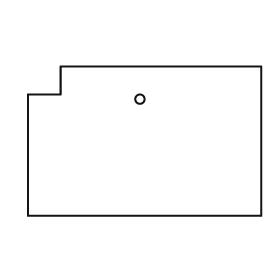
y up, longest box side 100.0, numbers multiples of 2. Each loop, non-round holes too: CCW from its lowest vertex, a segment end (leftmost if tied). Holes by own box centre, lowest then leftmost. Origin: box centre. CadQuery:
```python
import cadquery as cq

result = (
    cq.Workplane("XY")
    .moveTo(-50.0, -32.0)
    .lineTo(50.0, -32.0)
    .lineTo(50.0, 32.0)
    .lineTo(-36.0, 32.0)
    .lineTo(-36.0, 20.0)
    .lineTo(-50.0, 20.0)
    .close()
    .moveTo(-2.0, 18.0)
    .circle(2.0)
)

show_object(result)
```